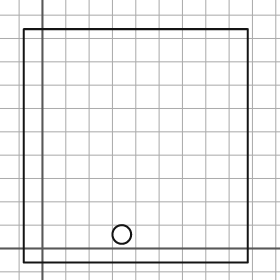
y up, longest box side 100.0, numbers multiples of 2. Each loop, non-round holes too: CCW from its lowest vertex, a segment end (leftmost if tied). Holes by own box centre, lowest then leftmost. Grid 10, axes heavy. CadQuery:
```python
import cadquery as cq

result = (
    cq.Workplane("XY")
    .moveTo(-8.0, -6.0)
    .lineTo(88.0, -6.0)
    .lineTo(88.0, 94.0)
    .lineTo(-8.0, 94.0)
    .close()
    .moveTo(34.0, 6.0)
    .circle(4.0)
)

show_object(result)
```